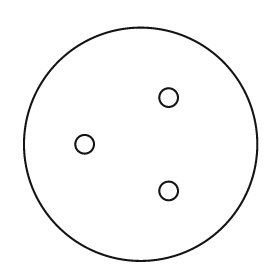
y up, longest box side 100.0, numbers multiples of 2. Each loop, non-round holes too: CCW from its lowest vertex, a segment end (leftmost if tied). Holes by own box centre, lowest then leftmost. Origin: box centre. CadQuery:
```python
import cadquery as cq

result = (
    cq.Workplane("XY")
    .moveTo(0.0, 0.0)
    .circle(50.0)
    .moveTo(12.0, -20.0)
    .circle(4.0)
    .moveTo(-24.0, 0.0)
    .circle(4.0)
    .moveTo(12.0, 20.0)
    .circle(4.0)
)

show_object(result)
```